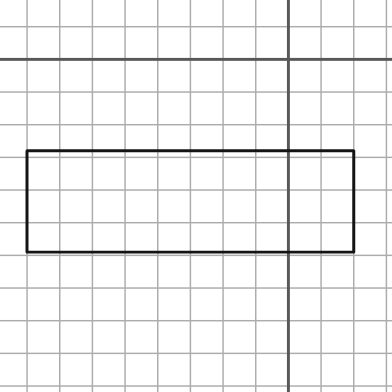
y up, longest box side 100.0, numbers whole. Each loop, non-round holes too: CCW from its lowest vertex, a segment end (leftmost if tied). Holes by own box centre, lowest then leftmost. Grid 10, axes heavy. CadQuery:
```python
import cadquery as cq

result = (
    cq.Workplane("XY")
    .moveTo(-80.0, -59.0)
    .lineTo(20.0, -59.0)
    .lineTo(20.0, -28.0)
    .lineTo(-80.0, -28.0)
    .close()
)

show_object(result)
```